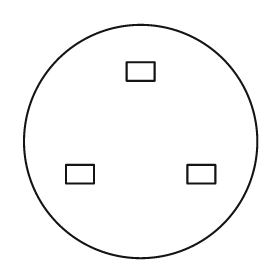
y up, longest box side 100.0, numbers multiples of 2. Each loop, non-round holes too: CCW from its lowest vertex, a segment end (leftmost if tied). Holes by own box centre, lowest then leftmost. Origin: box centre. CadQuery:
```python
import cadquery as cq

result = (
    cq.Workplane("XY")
    .moveTo(0.0, 0.0)
    .circle(50.0)
    .moveTo(-32.0, -18.0)
    .lineTo(-20.0, -18.0)
    .lineTo(-20.0, -10.0)
    .lineTo(-32.0, -10.0)
    .close()
    .moveTo(20.0, -18.0)
    .lineTo(32.0, -18.0)
    .lineTo(32.0, -10.0)
    .lineTo(20.0, -10.0)
    .close()
    .moveTo(-6.0, 26.0)
    .lineTo(6.0, 26.0)
    .lineTo(6.0, 34.0)
    .lineTo(-6.0, 34.0)
    .close()
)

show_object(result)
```